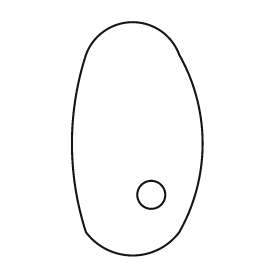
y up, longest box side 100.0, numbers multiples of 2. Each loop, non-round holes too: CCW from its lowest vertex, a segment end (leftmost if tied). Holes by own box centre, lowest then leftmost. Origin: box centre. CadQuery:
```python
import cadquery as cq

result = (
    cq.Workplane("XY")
    .moveTo(-22.0, -40.0)
    .threePointArc((-2.0, -50.0), (18.0, -40.0))
    .threePointArc((28.0, -2.0), (18.0, 36.0))
    .threePointArc((-2.0, 50.0), (-22.0, 36.0))
    .threePointArc((-28.0, -2.0), (-22.0, -40.0))
    .close()
    .moveTo(6.0, -24.0)
    .circle(6.0)
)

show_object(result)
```